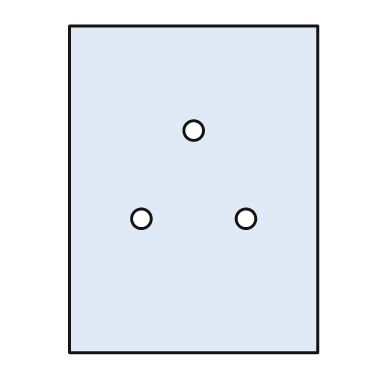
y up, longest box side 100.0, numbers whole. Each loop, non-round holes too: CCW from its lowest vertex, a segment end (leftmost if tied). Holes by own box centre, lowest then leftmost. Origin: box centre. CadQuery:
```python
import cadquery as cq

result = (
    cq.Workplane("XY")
    .moveTo(-38.0, -50.0)
    .lineTo(38.0, -50.0)
    .lineTo(38.0, 50.0)
    .lineTo(-38.0, 50.0)
    .close()
    .moveTo(-16.0, -9.0)
    .circle(3.0)
    .moveTo(16.0, -9.0)
    .circle(3.0)
    .moveTo(0.0, 18.0)
    .circle(3.0)
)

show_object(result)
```